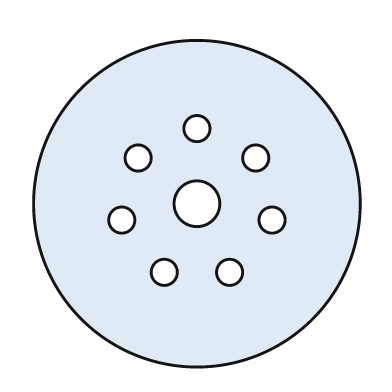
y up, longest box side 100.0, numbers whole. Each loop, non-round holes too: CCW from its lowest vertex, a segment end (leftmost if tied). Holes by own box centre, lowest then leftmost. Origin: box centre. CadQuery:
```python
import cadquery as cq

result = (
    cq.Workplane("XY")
    .moveTo(0.0, 0.0)
    .circle(50.0)
    .moveTo(-10.0, -21.0)
    .circle(4.0)
    .moveTo(10.0, -21.0)
    .circle(4.0)
    .moveTo(-23.0, -5.0)
    .circle(4.0)
    .moveTo(23.0, -5.0)
    .circle(4.0)
    .moveTo(0.0, 0.0)
    .circle(7.0)
    .moveTo(-18.0, 14.0)
    .circle(4.0)
    .moveTo(18.0, 14.0)
    .circle(4.0)
    .moveTo(0.0, 23.0)
    .circle(4.0)
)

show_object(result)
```